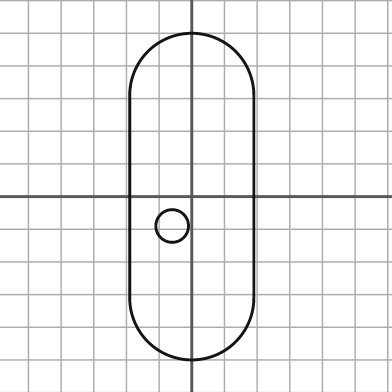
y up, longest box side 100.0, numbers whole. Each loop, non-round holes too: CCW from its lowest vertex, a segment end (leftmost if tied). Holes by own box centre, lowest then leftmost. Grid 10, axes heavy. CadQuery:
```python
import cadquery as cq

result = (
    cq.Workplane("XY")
    .moveTo(-19.0, -31.0)
    .threePointArc((0.0, -50.0), (19.0, -31.0))
    .lineTo(19.0, 31.0)
    .threePointArc((0.0, 50.0), (-19.0, 31.0))
    .close()
    .moveTo(-6.0, -9.0)
    .circle(5.0)
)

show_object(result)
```